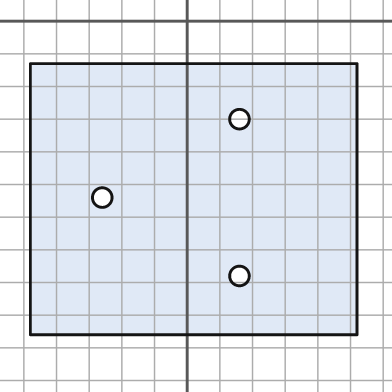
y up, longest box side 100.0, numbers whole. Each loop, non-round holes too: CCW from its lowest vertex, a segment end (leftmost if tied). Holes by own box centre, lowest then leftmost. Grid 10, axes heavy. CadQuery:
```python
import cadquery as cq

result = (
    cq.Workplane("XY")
    .moveTo(-48.0, -96.0)
    .lineTo(52.0, -96.0)
    .lineTo(52.0, -13.0)
    .lineTo(-48.0, -13.0)
    .close()
    .moveTo(16.0, -78.0)
    .circle(3.0)
    .moveTo(-26.0, -54.0)
    .circle(3.0)
    .moveTo(16.0, -30.0)
    .circle(3.0)
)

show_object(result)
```